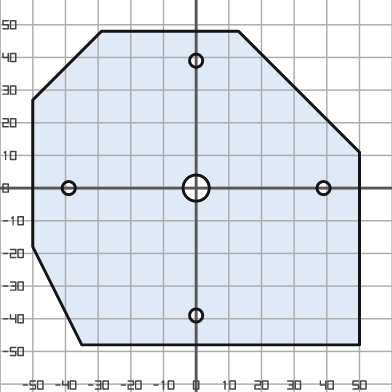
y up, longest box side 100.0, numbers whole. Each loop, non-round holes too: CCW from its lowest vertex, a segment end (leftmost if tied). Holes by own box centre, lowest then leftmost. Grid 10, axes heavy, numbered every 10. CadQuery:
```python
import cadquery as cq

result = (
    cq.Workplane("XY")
    .moveTo(-35.0, -48.0)
    .lineTo(50.0, -48.0)
    .lineTo(50.0, 11.0)
    .lineTo(13.0, 48.0)
    .lineTo(-29.0, 48.0)
    .lineTo(-50.0, 27.0)
    .lineTo(-50.0, -18.0)
    .close()
    .moveTo(0.0, -39.0)
    .circle(2.0)
    .moveTo(-39.0, 0.0)
    .circle(2.0)
    .moveTo(0.0, 0.0)
    .circle(4.0)
    .moveTo(39.0, 0.0)
    .circle(2.0)
    .moveTo(0.0, 39.0)
    .circle(2.0)
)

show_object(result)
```